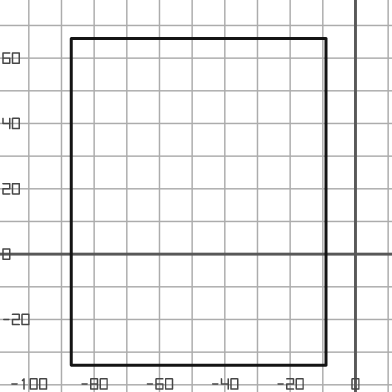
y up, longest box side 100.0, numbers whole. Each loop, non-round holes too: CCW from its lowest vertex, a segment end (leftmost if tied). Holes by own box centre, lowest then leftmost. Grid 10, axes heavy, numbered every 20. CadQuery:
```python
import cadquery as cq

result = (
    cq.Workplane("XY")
    .moveTo(-87.0, -34.0)
    .lineTo(-9.0, -34.0)
    .lineTo(-9.0, 66.0)
    .lineTo(-87.0, 66.0)
    .close()
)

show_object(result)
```